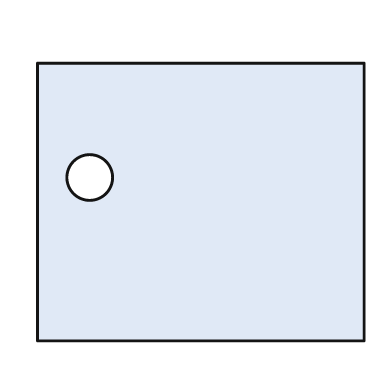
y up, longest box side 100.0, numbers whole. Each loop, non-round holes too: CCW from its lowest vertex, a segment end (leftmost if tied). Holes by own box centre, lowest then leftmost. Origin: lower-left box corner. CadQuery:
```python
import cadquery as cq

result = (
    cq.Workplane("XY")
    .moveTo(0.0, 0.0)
    .lineTo(100.0, 0.0)
    .lineTo(100.0, 85.0)
    .lineTo(0.0, 85.0)
    .close()
    .moveTo(16.0, 50.0)
    .circle(7.0)
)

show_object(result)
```